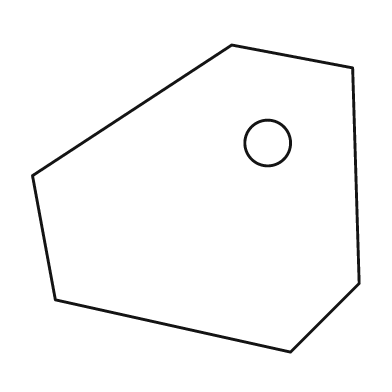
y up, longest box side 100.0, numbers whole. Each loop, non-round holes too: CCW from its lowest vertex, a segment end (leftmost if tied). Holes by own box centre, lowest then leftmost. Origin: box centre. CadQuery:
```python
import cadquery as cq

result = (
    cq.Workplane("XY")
    .moveTo(29.0, -47.0)
    .lineTo(50.0, -26.0)
    .lineTo(48.0, 40.0)
    .lineTo(11.0, 47.0)
    .lineTo(-50.0, 7.0)
    .lineTo(-43.0, -31.0)
    .close()
    .moveTo(22.0, 17.0)
    .circle(7.0)
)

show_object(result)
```